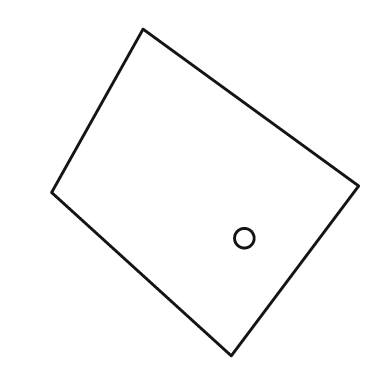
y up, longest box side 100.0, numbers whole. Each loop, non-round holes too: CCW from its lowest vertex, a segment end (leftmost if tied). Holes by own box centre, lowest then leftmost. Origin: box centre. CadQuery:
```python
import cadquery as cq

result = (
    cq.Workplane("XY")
    .moveTo(8.0, -50.0)
    .lineTo(47.0, 2.0)
    .lineTo(-19.0, 50.0)
    .lineTo(-47.0, 0.0)
    .close()
    .moveTo(12.0, -14.0)
    .circle(3.0)
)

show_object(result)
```